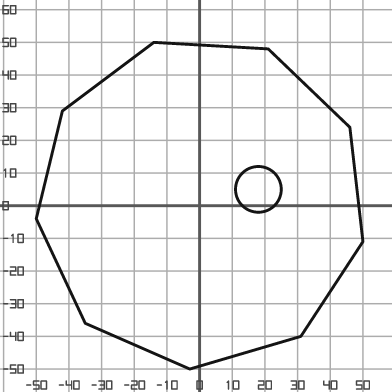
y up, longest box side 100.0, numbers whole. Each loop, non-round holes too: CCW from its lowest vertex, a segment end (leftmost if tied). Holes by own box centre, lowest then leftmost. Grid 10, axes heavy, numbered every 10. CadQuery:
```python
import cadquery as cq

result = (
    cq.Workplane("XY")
    .moveTo(-3.0, -50.0)
    .lineTo(31.0, -40.0)
    .lineTo(50.0, -11.0)
    .lineTo(46.0, 24.0)
    .lineTo(21.0, 48.0)
    .lineTo(-14.0, 50.0)
    .lineTo(-42.0, 29.0)
    .lineTo(-50.0, -4.0)
    .lineTo(-35.0, -36.0)
    .close()
    .moveTo(18.0, 5.0)
    .circle(7.0)
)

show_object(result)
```